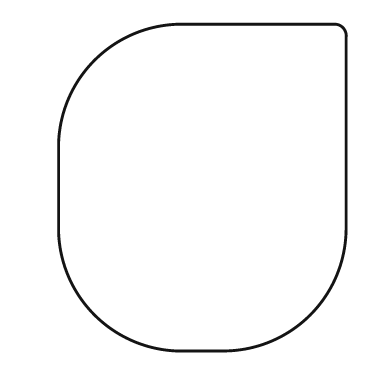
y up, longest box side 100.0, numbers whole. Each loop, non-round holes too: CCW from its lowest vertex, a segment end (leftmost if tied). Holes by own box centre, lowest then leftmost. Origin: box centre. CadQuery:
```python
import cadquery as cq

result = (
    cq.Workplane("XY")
    .moveTo(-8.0, -50.0)
    .lineTo(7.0, -50.0)
    .threePointArc((33.0, -39.0), (44.0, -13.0))
    .lineTo(44.0, 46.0)
    .threePointArc((43.0, 49.0), (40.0, 50.0))
    .lineTo(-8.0, 50.0)
    .threePointArc((-33.0, 39.0), (-44.0, 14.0))
    .lineTo(-44.0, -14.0)
    .threePointArc((-33.0, -39.0), (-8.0, -50.0))
    .close()
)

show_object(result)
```